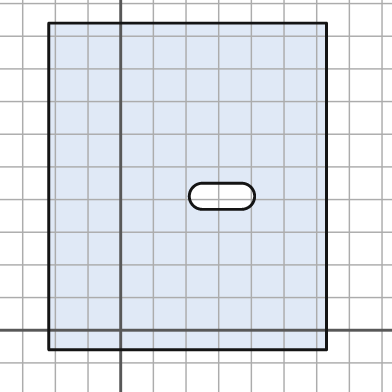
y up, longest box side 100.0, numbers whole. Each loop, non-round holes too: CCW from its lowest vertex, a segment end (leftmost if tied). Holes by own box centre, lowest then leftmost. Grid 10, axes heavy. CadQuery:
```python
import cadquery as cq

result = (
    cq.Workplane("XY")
    .moveTo(-22.0, -6.0)
    .lineTo(63.0, -6.0)
    .lineTo(63.0, 94.0)
    .lineTo(-22.0, 94.0)
    .close()
    .moveTo(25.0, 37.0)
    .lineTo(37.0, 37.0)
    .threePointArc((41.0, 41.0), (37.0, 45.0))
    .lineTo(25.0, 45.0)
    .threePointArc((21.0, 41.0), (25.0, 37.0))
    .close()
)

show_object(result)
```